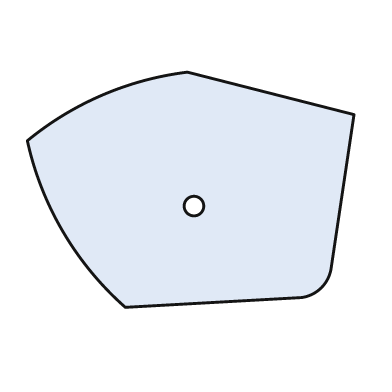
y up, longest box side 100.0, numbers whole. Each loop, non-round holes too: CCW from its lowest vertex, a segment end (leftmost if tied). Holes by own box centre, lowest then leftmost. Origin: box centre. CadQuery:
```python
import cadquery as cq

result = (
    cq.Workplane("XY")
    .moveTo(-20.0, -36.0)
    .lineTo(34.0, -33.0)
    .threePointArc((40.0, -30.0), (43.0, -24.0))
    .lineTo(50.0, 23.0)
    .lineTo(-1.0, 36.0)
    .threePointArc((-27.0, 29.0), (-50.0, 15.0))
    .threePointArc((-39.0, -13.0), (-20.0, -36.0))
    .close()
    .moveTo(1.0, -5.0)
    .circle(3.0)
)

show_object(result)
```